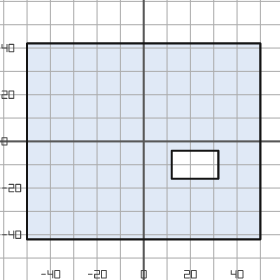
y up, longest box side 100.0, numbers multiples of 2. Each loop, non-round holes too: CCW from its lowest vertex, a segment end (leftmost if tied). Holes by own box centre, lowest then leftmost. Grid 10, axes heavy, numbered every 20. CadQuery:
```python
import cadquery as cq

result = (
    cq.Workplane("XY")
    .moveTo(-50.0, -42.0)
    .lineTo(50.0, -42.0)
    .lineTo(50.0, 42.0)
    .lineTo(-50.0, 42.0)
    .close()
    .moveTo(12.0, -16.0)
    .lineTo(32.0, -16.0)
    .lineTo(32.0, -4.0)
    .lineTo(12.0, -4.0)
    .close()
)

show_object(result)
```